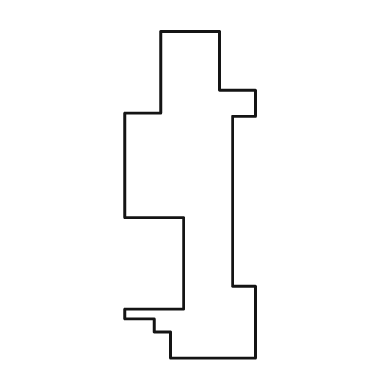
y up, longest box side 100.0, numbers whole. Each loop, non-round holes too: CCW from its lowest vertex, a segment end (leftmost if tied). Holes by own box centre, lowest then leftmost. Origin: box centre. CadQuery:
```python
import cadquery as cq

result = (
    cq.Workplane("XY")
    .moveTo(-6.0, -50.0)
    .lineTo(20.0, -50.0)
    .lineTo(20.0, -28.0)
    .lineTo(13.0, -28.0)
    .lineTo(13.0, 24.0)
    .lineTo(20.0, 24.0)
    .lineTo(20.0, 32.0)
    .lineTo(9.0, 32.0)
    .lineTo(9.0, 50.0)
    .lineTo(-9.0, 50.0)
    .lineTo(-9.0, 25.0)
    .lineTo(-20.0, 25.0)
    .lineTo(-20.0, -7.0)
    .lineTo(-2.0, -7.0)
    .lineTo(-2.0, -35.0)
    .lineTo(-20.0, -35.0)
    .lineTo(-20.0, -38.0)
    .lineTo(-11.0, -38.0)
    .lineTo(-11.0, -42.0)
    .lineTo(-6.0, -42.0)
    .close()
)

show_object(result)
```